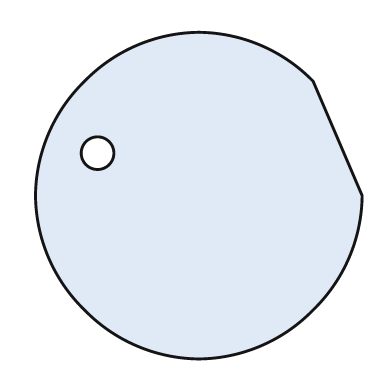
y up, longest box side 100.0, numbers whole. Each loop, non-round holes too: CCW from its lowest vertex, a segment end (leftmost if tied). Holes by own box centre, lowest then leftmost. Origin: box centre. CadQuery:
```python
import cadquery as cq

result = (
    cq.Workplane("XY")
    .moveTo(0.0, -50.0)
    .threePointArc((19.0, -46.0), (35.0, -35.0))
    .threePointArc((46.0, -19.0), (50.0, 0.0))
    .lineTo(35.0, 35.0)
    .threePointArc((19.0, 46.0), (0.0, 50.0))
    .threePointArc((-19.0, 46.0), (-35.0, 35.0))
    .threePointArc((-46.0, 19.0), (-50.0, 0.0))
    .threePointArc((-46.0, -19.0), (-35.0, -35.0))
    .threePointArc((-19.0, -46.0), (0.0, -50.0))
    .close()
    .moveTo(-31.0, 13.0)
    .circle(5.0)
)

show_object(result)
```